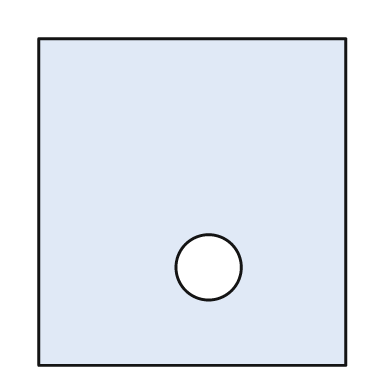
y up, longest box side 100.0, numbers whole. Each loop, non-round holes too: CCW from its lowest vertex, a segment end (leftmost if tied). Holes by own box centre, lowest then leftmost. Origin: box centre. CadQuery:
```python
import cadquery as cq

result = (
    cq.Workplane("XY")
    .moveTo(-47.0, -50.0)
    .lineTo(47.0, -50.0)
    .lineTo(47.0, 50.0)
    .lineTo(-47.0, 50.0)
    .close()
    .moveTo(5.0, -20.0)
    .circle(10.0)
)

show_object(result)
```